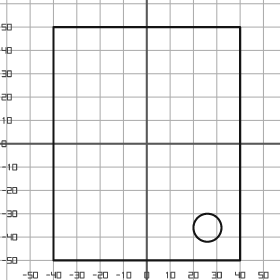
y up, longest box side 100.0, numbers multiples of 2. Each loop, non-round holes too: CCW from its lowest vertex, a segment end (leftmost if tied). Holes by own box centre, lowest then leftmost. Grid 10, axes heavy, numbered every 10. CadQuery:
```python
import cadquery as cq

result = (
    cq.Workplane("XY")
    .moveTo(-40.0, -50.0)
    .lineTo(40.0, -50.0)
    .lineTo(40.0, 50.0)
    .lineTo(-40.0, 50.0)
    .close()
    .moveTo(26.0, -36.0)
    .circle(6.0)
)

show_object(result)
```